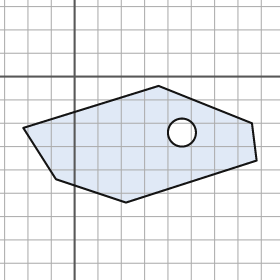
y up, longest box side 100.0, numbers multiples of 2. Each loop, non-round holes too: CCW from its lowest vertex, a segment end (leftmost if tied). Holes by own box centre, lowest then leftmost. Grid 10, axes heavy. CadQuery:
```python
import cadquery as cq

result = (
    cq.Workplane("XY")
    .moveTo(22.0, -54.0)
    .lineTo(78.0, -36.0)
    .lineTo(76.0, -20.0)
    .lineTo(36.0, -4.0)
    .lineTo(-22.0, -22.0)
    .lineTo(-8.0, -44.0)
    .close()
    .moveTo(46.0, -24.0)
    .circle(6.0)
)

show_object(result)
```